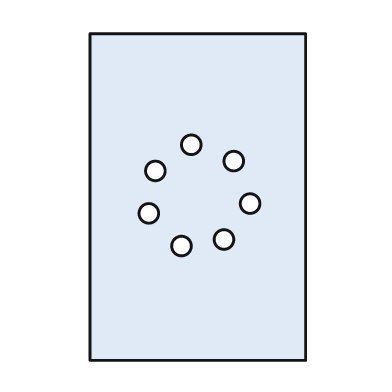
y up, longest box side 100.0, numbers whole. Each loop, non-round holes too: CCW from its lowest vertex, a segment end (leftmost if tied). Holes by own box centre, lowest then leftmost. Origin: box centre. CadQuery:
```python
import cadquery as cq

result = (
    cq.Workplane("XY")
    .moveTo(-33.0, -50.0)
    .lineTo(33.0, -50.0)
    .lineTo(33.0, 50.0)
    .lineTo(-33.0, 50.0)
    .close()
    .moveTo(-5.0, -15.0)
    .circle(3.0)
    .moveTo(8.0, -13.0)
    .circle(3.0)
    .moveTo(-15.0, -5.0)
    .circle(3.0)
    .moveTo(16.0, -2.0)
    .circle(3.0)
    .moveTo(-13.0, 8.0)
    .circle(3.0)
    .moveTo(11.0, 11.0)
    .circle(3.0)
    .moveTo(-2.0, 16.0)
    .circle(3.0)
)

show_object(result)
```